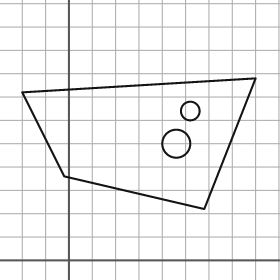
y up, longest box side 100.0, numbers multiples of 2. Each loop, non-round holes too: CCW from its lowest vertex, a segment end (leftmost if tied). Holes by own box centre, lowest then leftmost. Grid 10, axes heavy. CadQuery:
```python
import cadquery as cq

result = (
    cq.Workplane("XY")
    .moveTo(58.0, 22.0)
    .lineTo(80.0, 78.0)
    .lineTo(-20.0, 72.0)
    .lineTo(-2.0, 36.0)
    .close()
    .moveTo(46.0, 50.0)
    .circle(6.0)
    .moveTo(52.0, 64.0)
    .circle(4.0)
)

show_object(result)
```